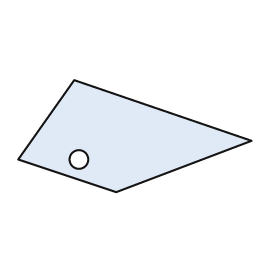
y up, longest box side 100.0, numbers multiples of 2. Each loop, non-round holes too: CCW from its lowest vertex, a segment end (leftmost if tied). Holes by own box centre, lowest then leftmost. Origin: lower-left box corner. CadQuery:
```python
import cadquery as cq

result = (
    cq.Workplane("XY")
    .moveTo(42.0, 0.0)
    .lineTo(100.0, 22.0)
    .lineTo(24.0, 48.0)
    .lineTo(0.0, 14.0)
    .close()
    .moveTo(26.0, 14.0)
    .circle(4.0)
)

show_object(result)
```